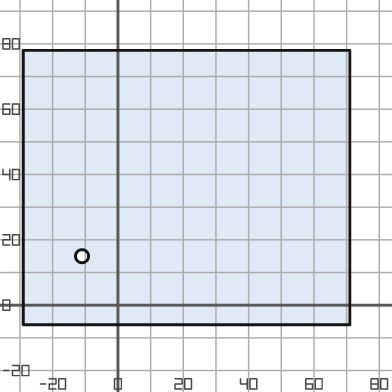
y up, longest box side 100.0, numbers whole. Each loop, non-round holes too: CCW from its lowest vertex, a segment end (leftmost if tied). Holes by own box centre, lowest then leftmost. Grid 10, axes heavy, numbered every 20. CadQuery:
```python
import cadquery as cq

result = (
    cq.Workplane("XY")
    .moveTo(-29.0, -6.0)
    .lineTo(71.0, -6.0)
    .lineTo(71.0, 78.0)
    .lineTo(-29.0, 78.0)
    .close()
    .moveTo(-11.0, 15.0)
    .circle(2.0)
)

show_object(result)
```